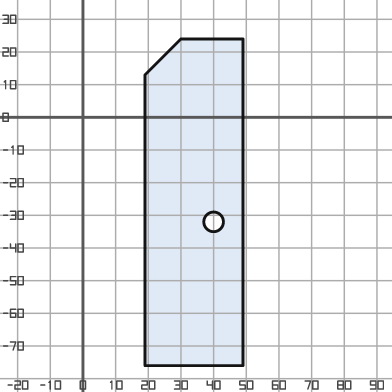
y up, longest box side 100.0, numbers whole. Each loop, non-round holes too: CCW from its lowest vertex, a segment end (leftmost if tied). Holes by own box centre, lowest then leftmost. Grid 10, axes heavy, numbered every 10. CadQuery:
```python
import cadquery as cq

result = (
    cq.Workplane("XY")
    .moveTo(19.0, -76.0)
    .lineTo(49.0, -76.0)
    .lineTo(49.0, 24.0)
    .lineTo(30.0, 24.0)
    .lineTo(19.0, 13.0)
    .close()
    .moveTo(40.0, -32.0)
    .circle(3.0)
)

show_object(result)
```